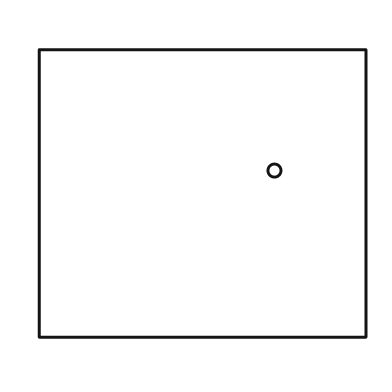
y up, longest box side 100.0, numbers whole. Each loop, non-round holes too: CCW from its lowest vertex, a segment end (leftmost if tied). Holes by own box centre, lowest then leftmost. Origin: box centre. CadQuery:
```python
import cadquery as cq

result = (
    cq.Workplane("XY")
    .moveTo(-50.0, -44.0)
    .lineTo(50.0, -44.0)
    .lineTo(50.0, 44.0)
    .lineTo(-50.0, 44.0)
    .close()
    .moveTo(22.0, 7.0)
    .circle(2.0)
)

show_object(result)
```